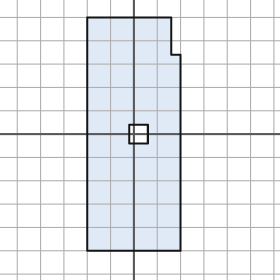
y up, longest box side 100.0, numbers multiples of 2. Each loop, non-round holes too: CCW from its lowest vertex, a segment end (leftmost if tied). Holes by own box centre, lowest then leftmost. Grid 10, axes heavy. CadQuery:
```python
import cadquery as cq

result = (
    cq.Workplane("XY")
    .moveTo(-20.0, -50.0)
    .lineTo(20.0, -50.0)
    .lineTo(20.0, 34.0)
    .lineTo(16.0, 34.0)
    .lineTo(16.0, 50.0)
    .lineTo(-20.0, 50.0)
    .close()
    .moveTo(-2.0, -4.0)
    .lineTo(6.0, -4.0)
    .lineTo(6.0, 4.0)
    .lineTo(-2.0, 4.0)
    .close()
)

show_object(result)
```